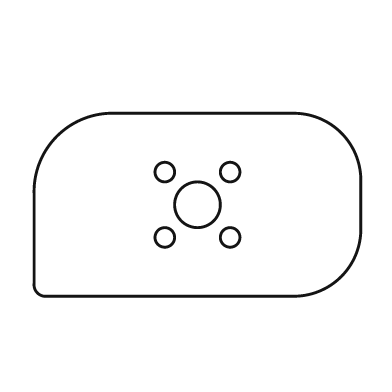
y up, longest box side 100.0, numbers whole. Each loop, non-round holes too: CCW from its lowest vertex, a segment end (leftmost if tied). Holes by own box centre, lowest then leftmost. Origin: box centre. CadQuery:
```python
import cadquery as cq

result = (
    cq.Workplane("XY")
    .moveTo(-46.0, -28.0)
    .lineTo(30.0, -28.0)
    .threePointArc((44.0, -22.0), (50.0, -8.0))
    .lineTo(50.0, 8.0)
    .threePointArc((44.0, 22.0), (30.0, 28.0))
    .lineTo(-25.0, 28.0)
    .threePointArc((-43.0, 21.0), (-50.0, 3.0))
    .lineTo(-50.0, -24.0)
    .threePointArc((-49.0, -27.0), (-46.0, -28.0))
    .close()
    .moveTo(-10.0, -10.0)
    .circle(3.0)
    .moveTo(10.0, -10.0)
    .circle(3.0)
    .moveTo(0.0, 0.0)
    .circle(7.0)
    .moveTo(-10.0, 10.0)
    .circle(3.0)
    .moveTo(10.0, 10.0)
    .circle(3.0)
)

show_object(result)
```